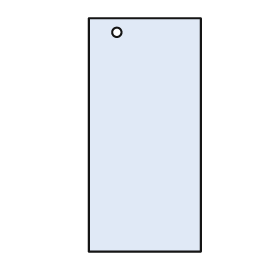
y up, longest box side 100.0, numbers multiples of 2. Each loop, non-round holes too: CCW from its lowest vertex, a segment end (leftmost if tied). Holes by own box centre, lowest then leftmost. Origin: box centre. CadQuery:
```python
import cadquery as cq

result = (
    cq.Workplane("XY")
    .moveTo(-24.0, -50.0)
    .lineTo(24.0, -50.0)
    .lineTo(24.0, 50.0)
    .lineTo(-24.0, 50.0)
    .close()
    .moveTo(-12.0, 44.0)
    .circle(2.0)
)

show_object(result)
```